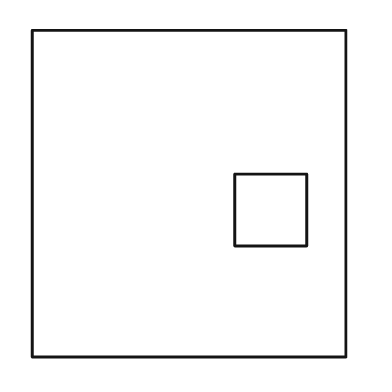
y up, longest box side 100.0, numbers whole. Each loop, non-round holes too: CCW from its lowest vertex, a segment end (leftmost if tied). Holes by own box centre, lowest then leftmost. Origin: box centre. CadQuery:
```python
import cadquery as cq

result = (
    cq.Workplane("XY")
    .moveTo(-48.0, -50.0)
    .lineTo(48.0, -50.0)
    .lineTo(48.0, 50.0)
    .lineTo(-48.0, 50.0)
    .close()
    .moveTo(14.0, -16.0)
    .lineTo(36.0, -16.0)
    .lineTo(36.0, 6.0)
    .lineTo(14.0, 6.0)
    .close()
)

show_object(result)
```